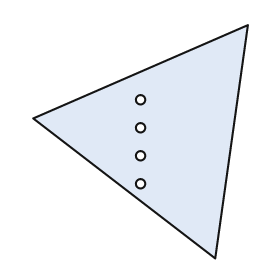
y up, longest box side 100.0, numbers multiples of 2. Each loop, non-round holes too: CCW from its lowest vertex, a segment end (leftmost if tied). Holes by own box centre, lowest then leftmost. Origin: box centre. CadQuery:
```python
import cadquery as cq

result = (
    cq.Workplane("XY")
    .moveTo(32.0, -50.0)
    .lineTo(46.0, 50.0)
    .lineTo(-46.0, 10.0)
    .close()
    .moveTo(0.0, -18.0)
    .circle(2.0)
    .moveTo(0.0, -6.0)
    .circle(2.0)
    .moveTo(0.0, 6.0)
    .circle(2.0)
    .moveTo(0.0, 18.0)
    .circle(2.0)
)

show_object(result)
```